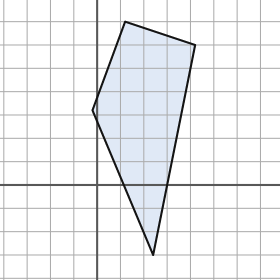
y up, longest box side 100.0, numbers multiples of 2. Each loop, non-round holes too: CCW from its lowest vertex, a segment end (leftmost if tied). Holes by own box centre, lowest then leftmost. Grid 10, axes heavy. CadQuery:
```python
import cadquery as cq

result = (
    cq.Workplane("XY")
    .moveTo(24.0, -30.0)
    .lineTo(42.0, 60.0)
    .lineTo(12.0, 70.0)
    .lineTo(-2.0, 32.0)
    .close()
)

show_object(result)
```